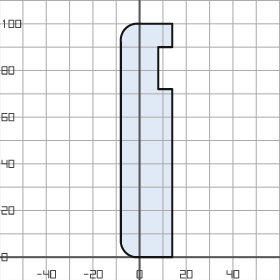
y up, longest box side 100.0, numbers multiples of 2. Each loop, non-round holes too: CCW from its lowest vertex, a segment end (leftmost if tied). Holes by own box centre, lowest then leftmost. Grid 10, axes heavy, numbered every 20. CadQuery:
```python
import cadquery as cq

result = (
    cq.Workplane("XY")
    .moveTo(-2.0, 0.0)
    .lineTo(14.0, 0.0)
    .lineTo(14.0, 72.0)
    .lineTo(8.0, 72.0)
    .lineTo(8.0, 90.0)
    .lineTo(14.0, 90.0)
    .lineTo(14.0, 100.0)
    .lineTo(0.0, 100.0)
    .threePointArc((-6.0, 98.0), (-8.0, 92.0))
    .lineTo(-8.0, 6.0)
    .threePointArc((-6.0, 2.0), (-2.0, 0.0))
    .close()
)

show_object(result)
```